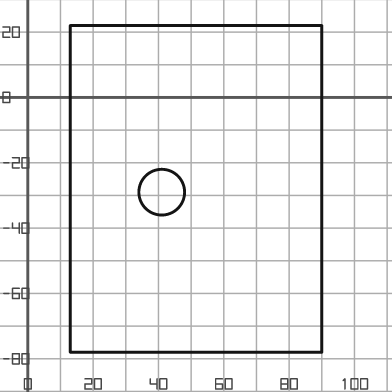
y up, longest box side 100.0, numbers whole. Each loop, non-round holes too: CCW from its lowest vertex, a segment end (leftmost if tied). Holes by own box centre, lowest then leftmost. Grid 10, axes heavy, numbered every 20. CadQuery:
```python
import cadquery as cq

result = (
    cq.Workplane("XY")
    .moveTo(13.0, -78.0)
    .lineTo(90.0, -78.0)
    .lineTo(90.0, 22.0)
    .lineTo(13.0, 22.0)
    .close()
    .moveTo(41.0, -29.0)
    .circle(7.0)
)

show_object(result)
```